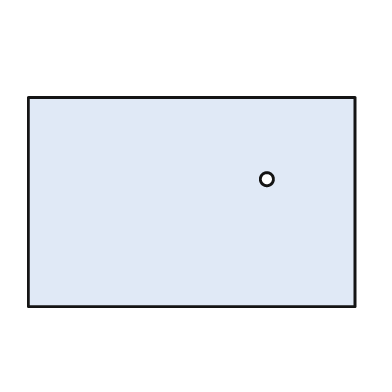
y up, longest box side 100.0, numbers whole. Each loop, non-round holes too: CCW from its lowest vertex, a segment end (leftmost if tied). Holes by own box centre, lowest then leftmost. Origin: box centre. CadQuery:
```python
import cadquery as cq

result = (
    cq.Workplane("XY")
    .moveTo(-50.0, -32.0)
    .lineTo(50.0, -32.0)
    .lineTo(50.0, 32.0)
    .lineTo(-50.0, 32.0)
    .close()
    .moveTo(23.0, 7.0)
    .circle(2.0)
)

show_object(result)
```